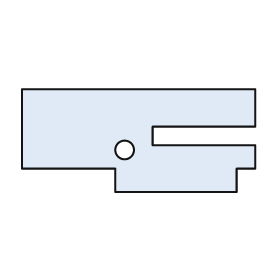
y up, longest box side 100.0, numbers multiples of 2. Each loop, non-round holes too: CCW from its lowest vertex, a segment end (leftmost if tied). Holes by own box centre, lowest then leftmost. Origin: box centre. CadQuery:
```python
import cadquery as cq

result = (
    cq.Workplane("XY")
    .moveTo(-10.0, -22.0)
    .lineTo(42.0, -22.0)
    .lineTo(42.0, -12.0)
    .lineTo(50.0, -12.0)
    .lineTo(50.0, -2.0)
    .lineTo(6.0, -2.0)
    .lineTo(6.0, 6.0)
    .lineTo(50.0, 6.0)
    .lineTo(50.0, 22.0)
    .lineTo(-50.0, 22.0)
    .lineTo(-50.0, -12.0)
    .lineTo(-10.0, -12.0)
    .close()
    .moveTo(-6.0, -4.0)
    .circle(4.0)
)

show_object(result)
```